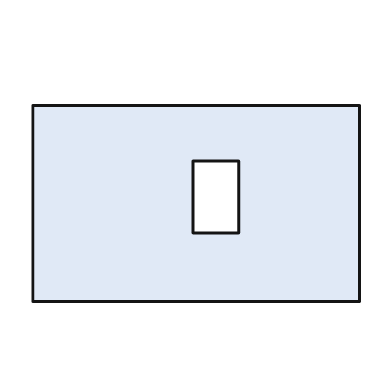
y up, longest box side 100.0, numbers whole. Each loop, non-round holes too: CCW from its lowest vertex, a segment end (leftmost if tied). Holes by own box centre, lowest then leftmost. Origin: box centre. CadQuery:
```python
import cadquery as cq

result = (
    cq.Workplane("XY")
    .moveTo(-50.0, -30.0)
    .lineTo(50.0, -30.0)
    .lineTo(50.0, 30.0)
    .lineTo(-50.0, 30.0)
    .close()
    .moveTo(-1.0, -9.0)
    .lineTo(13.0, -9.0)
    .lineTo(13.0, 13.0)
    .lineTo(-1.0, 13.0)
    .close()
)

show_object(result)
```